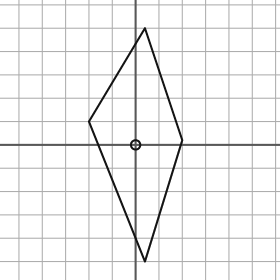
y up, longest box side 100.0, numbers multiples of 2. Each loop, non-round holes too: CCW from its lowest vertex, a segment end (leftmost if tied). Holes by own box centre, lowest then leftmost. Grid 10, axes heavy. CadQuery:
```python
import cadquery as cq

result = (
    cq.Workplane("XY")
    .moveTo(4.0, -50.0)
    .lineTo(20.0, 2.0)
    .lineTo(4.0, 50.0)
    .lineTo(-20.0, 10.0)
    .close()
    .moveTo(0.0, 0.0)
    .circle(2.0)
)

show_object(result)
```